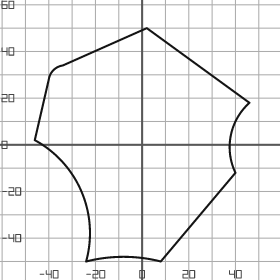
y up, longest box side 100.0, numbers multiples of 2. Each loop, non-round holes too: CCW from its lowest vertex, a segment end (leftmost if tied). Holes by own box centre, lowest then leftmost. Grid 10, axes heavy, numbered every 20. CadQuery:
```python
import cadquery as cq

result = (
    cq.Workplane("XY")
    .moveTo(-24.0, -50.0)
    .threePointArc((-8.0, -48.0), (8.0, -50.0))
    .lineTo(40.0, -12.0)
    .threePointArc((38.0, 4.0), (46.0, 18.0))
    .lineTo(2.0, 50.0)
    .lineTo(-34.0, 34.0)
    .threePointArc((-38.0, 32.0), (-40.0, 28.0))
    .lineTo(-46.0, 2.0)
    .threePointArc((-26.0, -20.0), (-24.0, -50.0))
    .close()
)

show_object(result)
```